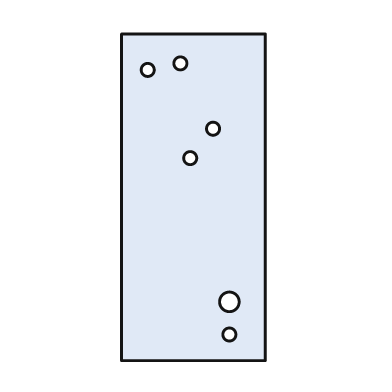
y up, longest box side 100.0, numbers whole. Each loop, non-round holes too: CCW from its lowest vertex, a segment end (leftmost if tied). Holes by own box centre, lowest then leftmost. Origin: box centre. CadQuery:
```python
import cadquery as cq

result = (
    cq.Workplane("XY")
    .moveTo(-22.0, -50.0)
    .lineTo(22.0, -50.0)
    .lineTo(22.0, 50.0)
    .lineTo(-22.0, 50.0)
    .close()
    .moveTo(11.0, -42.0)
    .circle(2.0)
    .moveTo(11.0, -32.0)
    .circle(3.0)
    .moveTo(-1.0, 12.0)
    .circle(2.0)
    .moveTo(6.0, 21.0)
    .circle(2.0)
    .moveTo(-14.0, 39.0)
    .circle(2.0)
    .moveTo(-4.0, 41.0)
    .circle(2.0)
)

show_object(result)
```